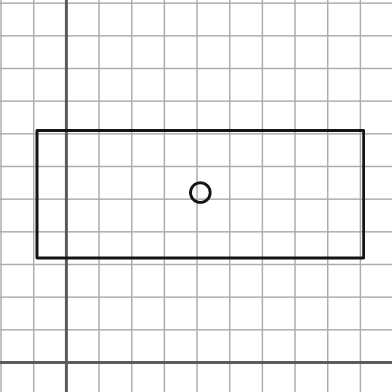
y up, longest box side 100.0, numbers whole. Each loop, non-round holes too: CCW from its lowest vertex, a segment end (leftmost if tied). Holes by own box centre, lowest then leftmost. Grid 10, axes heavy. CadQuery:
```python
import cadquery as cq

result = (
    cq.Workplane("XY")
    .moveTo(-9.0, 32.0)
    .lineTo(91.0, 32.0)
    .lineTo(91.0, 71.0)
    .lineTo(-9.0, 71.0)
    .close()
    .moveTo(41.0, 52.0)
    .circle(3.0)
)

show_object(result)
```